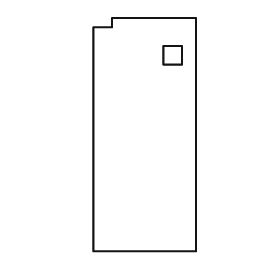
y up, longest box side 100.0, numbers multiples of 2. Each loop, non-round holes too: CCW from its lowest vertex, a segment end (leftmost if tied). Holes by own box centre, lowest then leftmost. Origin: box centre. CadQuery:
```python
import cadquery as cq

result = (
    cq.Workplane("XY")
    .moveTo(-22.0, -50.0)
    .lineTo(22.0, -50.0)
    .lineTo(22.0, 50.0)
    .lineTo(-14.0, 50.0)
    .lineTo(-14.0, 46.0)
    .lineTo(-22.0, 46.0)
    .close()
    .moveTo(8.0, 30.0)
    .lineTo(16.0, 30.0)
    .lineTo(16.0, 38.0)
    .lineTo(8.0, 38.0)
    .close()
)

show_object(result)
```